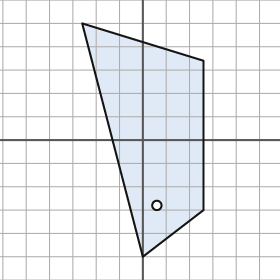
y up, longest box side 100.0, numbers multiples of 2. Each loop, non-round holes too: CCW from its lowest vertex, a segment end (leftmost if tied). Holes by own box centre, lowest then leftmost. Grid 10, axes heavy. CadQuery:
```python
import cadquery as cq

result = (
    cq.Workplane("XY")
    .moveTo(0.0, -50.0)
    .lineTo(26.0, -30.0)
    .lineTo(26.0, 34.0)
    .lineTo(-26.0, 50.0)
    .close()
    .moveTo(6.0, -28.0)
    .circle(2.0)
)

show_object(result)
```